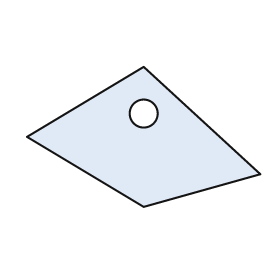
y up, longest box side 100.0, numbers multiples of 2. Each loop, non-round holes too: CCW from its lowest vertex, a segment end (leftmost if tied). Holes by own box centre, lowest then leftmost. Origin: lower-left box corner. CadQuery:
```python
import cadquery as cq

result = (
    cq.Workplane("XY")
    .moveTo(50.0, 0.0)
    .lineTo(100.0, 14.0)
    .lineTo(50.0, 60.0)
    .lineTo(0.0, 30.0)
    .close()
    .moveTo(50.0, 40.0)
    .circle(6.0)
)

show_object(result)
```